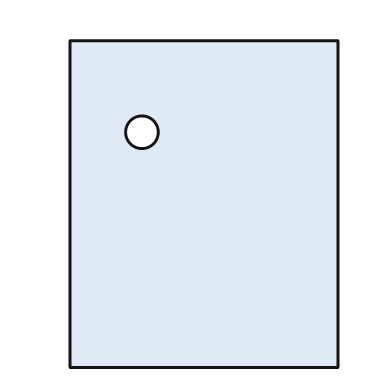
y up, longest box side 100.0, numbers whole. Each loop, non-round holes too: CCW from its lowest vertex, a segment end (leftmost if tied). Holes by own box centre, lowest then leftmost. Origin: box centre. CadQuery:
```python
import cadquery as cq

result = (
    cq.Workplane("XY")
    .moveTo(-41.0, -50.0)
    .lineTo(41.0, -50.0)
    .lineTo(41.0, 50.0)
    .lineTo(-41.0, 50.0)
    .close()
    .moveTo(-19.0, 22.0)
    .circle(5.0)
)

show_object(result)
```